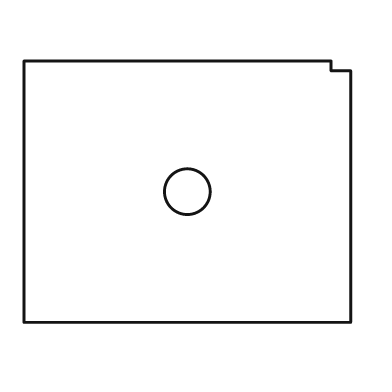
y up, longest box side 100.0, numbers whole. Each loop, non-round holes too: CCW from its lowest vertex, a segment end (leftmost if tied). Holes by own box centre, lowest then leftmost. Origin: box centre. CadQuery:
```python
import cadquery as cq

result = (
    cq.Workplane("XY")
    .moveTo(-50.0, -40.0)
    .lineTo(50.0, -40.0)
    .lineTo(50.0, 37.0)
    .lineTo(44.0, 37.0)
    .lineTo(44.0, 40.0)
    .lineTo(-50.0, 40.0)
    .close()
    .moveTo(0.0, 0.0)
    .circle(7.0)
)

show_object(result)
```